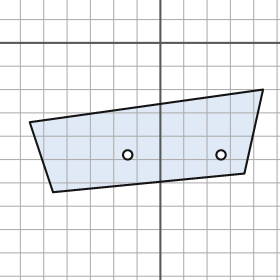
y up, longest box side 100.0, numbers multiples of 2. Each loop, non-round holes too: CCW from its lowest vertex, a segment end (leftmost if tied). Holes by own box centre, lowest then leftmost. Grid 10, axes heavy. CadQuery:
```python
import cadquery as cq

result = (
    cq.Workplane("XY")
    .moveTo(-46.0, -64.0)
    .lineTo(36.0, -56.0)
    .lineTo(44.0, -20.0)
    .lineTo(-56.0, -34.0)
    .close()
    .moveTo(-14.0, -48.0)
    .circle(2.0)
    .moveTo(26.0, -48.0)
    .circle(2.0)
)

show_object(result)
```